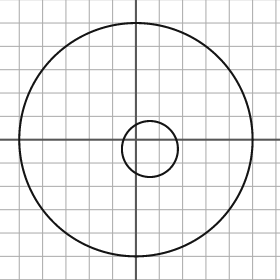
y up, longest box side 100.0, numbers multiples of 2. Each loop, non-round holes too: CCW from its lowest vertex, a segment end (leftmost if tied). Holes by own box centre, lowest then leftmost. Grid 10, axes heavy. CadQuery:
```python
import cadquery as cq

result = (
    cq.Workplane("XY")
    .moveTo(0.0, 0.0)
    .circle(50.0)
    .moveTo(6.0, -4.0)
    .circle(12.0)
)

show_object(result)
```